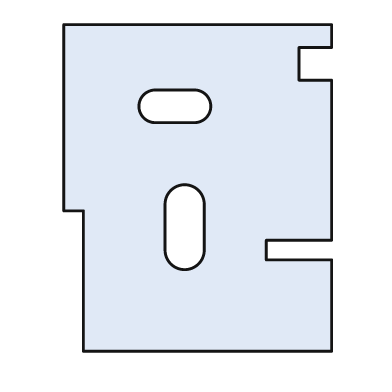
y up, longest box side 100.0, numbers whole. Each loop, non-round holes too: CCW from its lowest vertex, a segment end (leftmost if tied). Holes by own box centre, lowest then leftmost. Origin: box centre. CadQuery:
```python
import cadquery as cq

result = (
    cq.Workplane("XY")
    .moveTo(-35.0, -50.0)
    .lineTo(41.0, -50.0)
    .lineTo(41.0, -22.0)
    .lineTo(21.0, -22.0)
    .lineTo(21.0, -16.0)
    .lineTo(41.0, -16.0)
    .lineTo(41.0, 33.0)
    .lineTo(31.0, 33.0)
    .lineTo(31.0, 43.0)
    .lineTo(41.0, 43.0)
    .lineTo(41.0, 50.0)
    .lineTo(-41.0, 50.0)
    .lineTo(-41.0, -7.0)
    .lineTo(-35.0, -7.0)
    .close()
    .moveTo(-10.0, -19.0)
    .threePointArc((-4.0, -25.0), (2.0, -19.0))
    .lineTo(2.0, -5.0)
    .threePointArc((-4.0, 1.0), (-10.0, -5.0))
    .close()
    .moveTo(-13.0, 20.0)
    .lineTo(-1.0, 20.0)
    .threePointArc((4.0, 25.0), (-1.0, 30.0))
    .lineTo(-13.0, 30.0)
    .threePointArc((-18.0, 25.0), (-13.0, 20.0))
    .close()
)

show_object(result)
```